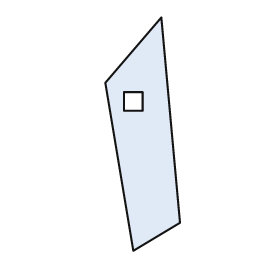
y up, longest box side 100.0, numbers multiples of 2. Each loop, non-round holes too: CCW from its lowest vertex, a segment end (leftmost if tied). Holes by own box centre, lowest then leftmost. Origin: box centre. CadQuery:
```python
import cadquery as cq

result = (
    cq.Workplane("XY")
    .moveTo(-4.0, -50.0)
    .lineTo(16.0, -38.0)
    .lineTo(8.0, 50.0)
    .lineTo(-16.0, 22.0)
    .close()
    .moveTo(-8.0, 10.0)
    .lineTo(0.0, 10.0)
    .lineTo(0.0, 18.0)
    .lineTo(-8.0, 18.0)
    .close()
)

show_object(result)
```